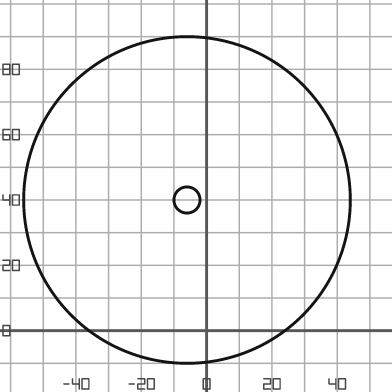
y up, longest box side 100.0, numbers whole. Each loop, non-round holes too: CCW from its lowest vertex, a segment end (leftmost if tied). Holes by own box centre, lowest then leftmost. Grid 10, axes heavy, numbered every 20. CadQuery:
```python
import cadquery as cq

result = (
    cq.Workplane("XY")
    .moveTo(-6.0, 40.0)
    .circle(50.0)
    .moveTo(-6.0, 40.0)
    .circle(4.0)
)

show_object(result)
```